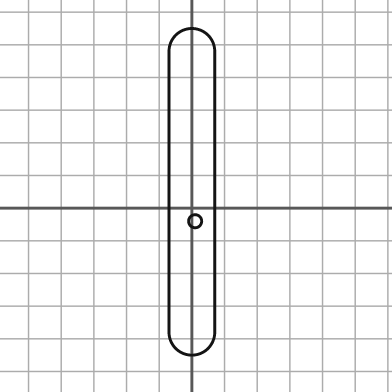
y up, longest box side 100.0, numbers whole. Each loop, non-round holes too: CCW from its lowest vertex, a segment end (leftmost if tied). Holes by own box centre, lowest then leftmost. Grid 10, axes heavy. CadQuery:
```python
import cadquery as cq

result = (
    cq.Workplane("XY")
    .moveTo(-7.0, -38.0)
    .threePointArc((0.0, -45.0), (7.0, -38.0))
    .lineTo(7.0, 48.0)
    .threePointArc((0.0, 55.0), (-7.0, 48.0))
    .close()
    .moveTo(1.0, -4.0)
    .circle(2.0)
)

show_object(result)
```